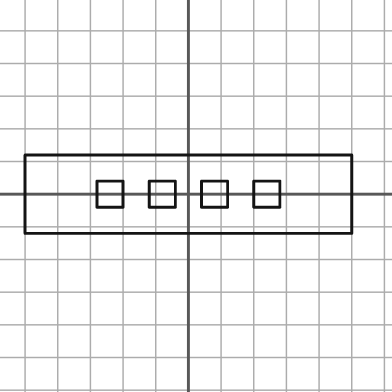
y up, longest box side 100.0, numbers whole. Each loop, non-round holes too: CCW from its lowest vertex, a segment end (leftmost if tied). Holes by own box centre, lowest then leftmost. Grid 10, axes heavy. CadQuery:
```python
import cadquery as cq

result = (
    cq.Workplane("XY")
    .moveTo(-50.0, -12.0)
    .lineTo(50.0, -12.0)
    .lineTo(50.0, 12.0)
    .lineTo(-50.0, 12.0)
    .close()
    .moveTo(-28.0, -4.0)
    .lineTo(-20.0, -4.0)
    .lineTo(-20.0, 4.0)
    .lineTo(-28.0, 4.0)
    .close()
    .moveTo(-12.0, -4.0)
    .lineTo(-4.0, -4.0)
    .lineTo(-4.0, 4.0)
    .lineTo(-12.0, 4.0)
    .close()
    .moveTo(4.0, -4.0)
    .lineTo(12.0, -4.0)
    .lineTo(12.0, 4.0)
    .lineTo(4.0, 4.0)
    .close()
    .moveTo(20.0, -4.0)
    .lineTo(28.0, -4.0)
    .lineTo(28.0, 4.0)
    .lineTo(20.0, 4.0)
    .close()
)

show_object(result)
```